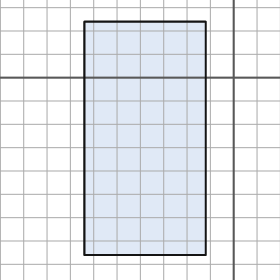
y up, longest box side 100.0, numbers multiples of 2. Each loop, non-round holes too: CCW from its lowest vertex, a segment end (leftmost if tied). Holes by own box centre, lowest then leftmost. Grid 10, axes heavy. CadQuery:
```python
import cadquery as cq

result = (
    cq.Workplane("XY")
    .moveTo(-64.0, -76.0)
    .lineTo(-12.0, -76.0)
    .lineTo(-12.0, 24.0)
    .lineTo(-64.0, 24.0)
    .close()
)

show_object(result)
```